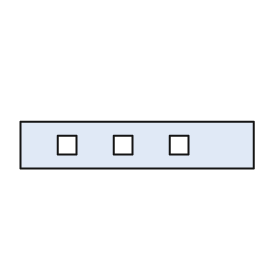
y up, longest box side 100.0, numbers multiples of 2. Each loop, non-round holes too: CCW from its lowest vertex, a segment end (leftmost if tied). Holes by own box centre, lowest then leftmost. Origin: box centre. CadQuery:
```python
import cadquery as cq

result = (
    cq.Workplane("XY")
    .moveTo(-50.0, -10.0)
    .lineTo(50.0, -10.0)
    .lineTo(50.0, 10.0)
    .lineTo(-50.0, 10.0)
    .close()
    .moveTo(-34.0, -4.0)
    .lineTo(-26.0, -4.0)
    .lineTo(-26.0, 4.0)
    .lineTo(-34.0, 4.0)
    .close()
    .moveTo(-10.0, -4.0)
    .lineTo(-2.0, -4.0)
    .lineTo(-2.0, 4.0)
    .lineTo(-10.0, 4.0)
    .close()
    .moveTo(14.0, -4.0)
    .lineTo(22.0, -4.0)
    .lineTo(22.0, 4.0)
    .lineTo(14.0, 4.0)
    .close()
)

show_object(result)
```